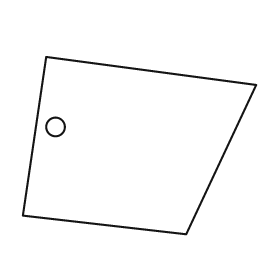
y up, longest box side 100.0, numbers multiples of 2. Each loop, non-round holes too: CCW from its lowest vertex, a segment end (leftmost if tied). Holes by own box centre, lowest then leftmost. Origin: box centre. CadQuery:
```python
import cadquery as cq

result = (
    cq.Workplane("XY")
    .moveTo(20.0, -38.0)
    .lineTo(50.0, 26.0)
    .lineTo(-40.0, 38.0)
    .lineTo(-50.0, -30.0)
    .close()
    .moveTo(-36.0, 8.0)
    .circle(4.0)
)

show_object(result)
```